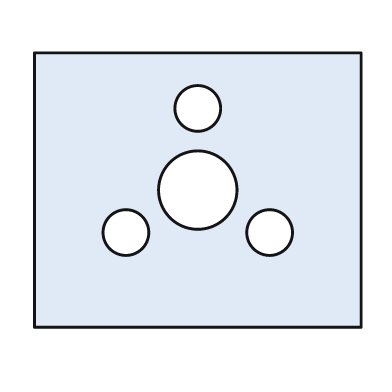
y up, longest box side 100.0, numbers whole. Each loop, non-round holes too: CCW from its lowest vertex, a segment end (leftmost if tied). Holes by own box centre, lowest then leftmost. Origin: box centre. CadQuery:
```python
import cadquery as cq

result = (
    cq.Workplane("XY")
    .moveTo(-50.0, -42.0)
    .lineTo(50.0, -42.0)
    .lineTo(50.0, 42.0)
    .lineTo(-50.0, 42.0)
    .close()
    .moveTo(-22.0, -13.0)
    .circle(7.0)
    .moveTo(22.0, -13.0)
    .circle(7.0)
    .moveTo(0.0, 0.0)
    .circle(12.0)
    .moveTo(0.0, 25.0)
    .circle(7.0)
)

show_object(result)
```